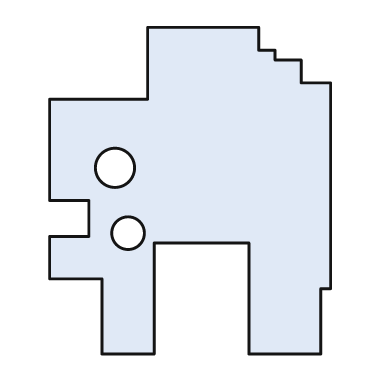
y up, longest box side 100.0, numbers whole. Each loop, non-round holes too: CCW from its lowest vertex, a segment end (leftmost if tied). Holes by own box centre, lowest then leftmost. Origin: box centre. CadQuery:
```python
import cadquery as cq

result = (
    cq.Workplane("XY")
    .moveTo(-27.0, -50.0)
    .lineTo(-11.0, -50.0)
    .lineTo(-11.0, -16.0)
    .lineTo(18.0, -16.0)
    .lineTo(18.0, -50.0)
    .lineTo(40.0, -50.0)
    .lineTo(40.0, -30.0)
    .lineTo(43.0, -30.0)
    .lineTo(43.0, 33.0)
    .lineTo(34.0, 33.0)
    .lineTo(34.0, 40.0)
    .lineTo(26.0, 40.0)
    .lineTo(26.0, 43.0)
    .lineTo(21.0, 43.0)
    .lineTo(21.0, 50.0)
    .lineTo(-13.0, 50.0)
    .lineTo(-13.0, 28.0)
    .lineTo(-43.0, 28.0)
    .lineTo(-43.0, -3.0)
    .lineTo(-31.0, -3.0)
    .lineTo(-31.0, -14.0)
    .lineTo(-43.0, -14.0)
    .lineTo(-43.0, -27.0)
    .lineTo(-27.0, -27.0)
    .close()
    .moveTo(-19.0, -13.0)
    .circle(5.0)
    .moveTo(-23.0, 7.0)
    .circle(6.0)
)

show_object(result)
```